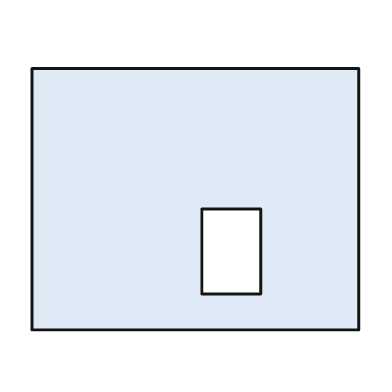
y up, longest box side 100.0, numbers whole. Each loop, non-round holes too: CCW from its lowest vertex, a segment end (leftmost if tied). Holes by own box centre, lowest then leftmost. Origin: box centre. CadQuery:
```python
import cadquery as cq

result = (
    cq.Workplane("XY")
    .moveTo(-50.0, -40.0)
    .lineTo(50.0, -40.0)
    .lineTo(50.0, 40.0)
    .lineTo(-50.0, 40.0)
    .close()
    .moveTo(2.0, -29.0)
    .lineTo(20.0, -29.0)
    .lineTo(20.0, -3.0)
    .lineTo(2.0, -3.0)
    .close()
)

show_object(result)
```